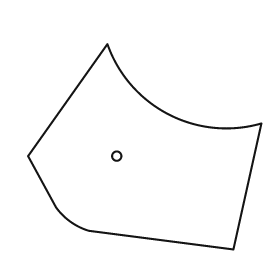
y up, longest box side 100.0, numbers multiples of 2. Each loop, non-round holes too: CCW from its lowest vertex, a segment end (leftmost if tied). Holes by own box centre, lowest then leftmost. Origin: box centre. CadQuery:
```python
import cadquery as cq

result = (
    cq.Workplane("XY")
    .moveTo(38.0, -44.0)
    .lineTo(50.0, 10.0)
    .threePointArc((10.0, 14.0), (-16.0, 44.0))
    .lineTo(-50.0, -4.0)
    .lineTo(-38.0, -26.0)
    .threePointArc((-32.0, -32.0), (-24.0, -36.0))
    .close()
    .moveTo(-12.0, -4.0)
    .circle(2.0)
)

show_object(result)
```